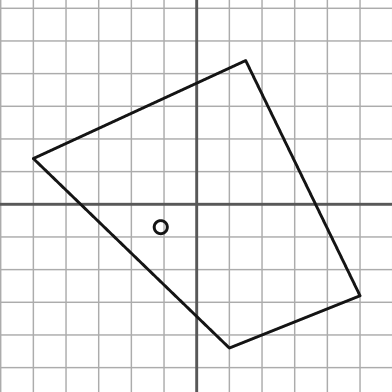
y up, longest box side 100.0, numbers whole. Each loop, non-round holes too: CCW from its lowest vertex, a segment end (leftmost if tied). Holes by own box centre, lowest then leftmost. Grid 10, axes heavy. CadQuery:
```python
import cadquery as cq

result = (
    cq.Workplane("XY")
    .moveTo(10.0, -44.0)
    .lineTo(50.0, -28.0)
    .lineTo(15.0, 44.0)
    .lineTo(-50.0, 14.0)
    .close()
    .moveTo(-11.0, -7.0)
    .circle(2.0)
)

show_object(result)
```